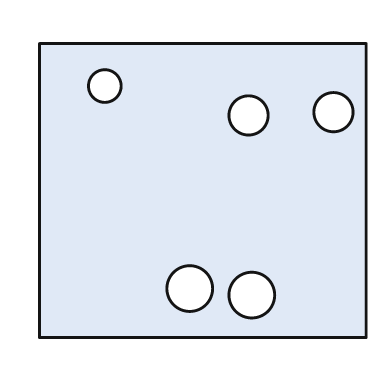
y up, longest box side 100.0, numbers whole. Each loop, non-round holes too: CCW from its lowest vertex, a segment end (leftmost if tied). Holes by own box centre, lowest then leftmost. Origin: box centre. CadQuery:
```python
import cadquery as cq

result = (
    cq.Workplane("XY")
    .moveTo(-50.0, -45.0)
    .lineTo(50.0, -45.0)
    .lineTo(50.0, 45.0)
    .lineTo(-50.0, 45.0)
    .close()
    .moveTo(15.0, -32.0)
    .circle(7.0)
    .moveTo(-4.0, -30.0)
    .circle(7.0)
    .moveTo(14.0, 23.0)
    .circle(6.0)
    .moveTo(40.0, 24.0)
    .circle(6.0)
    .moveTo(-30.0, 32.0)
    .circle(5.0)
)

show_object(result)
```